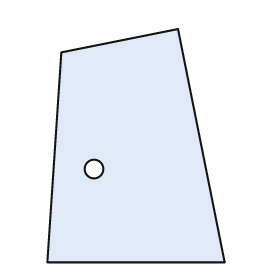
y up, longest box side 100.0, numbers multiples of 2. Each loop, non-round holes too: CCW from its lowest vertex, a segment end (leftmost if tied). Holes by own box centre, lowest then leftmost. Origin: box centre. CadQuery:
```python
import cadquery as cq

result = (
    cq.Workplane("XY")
    .moveTo(-38.0, -50.0)
    .lineTo(38.0, -50.0)
    .lineTo(18.0, 50.0)
    .lineTo(-32.0, 40.0)
    .close()
    .moveTo(-18.0, -10.0)
    .circle(4.0)
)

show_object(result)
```